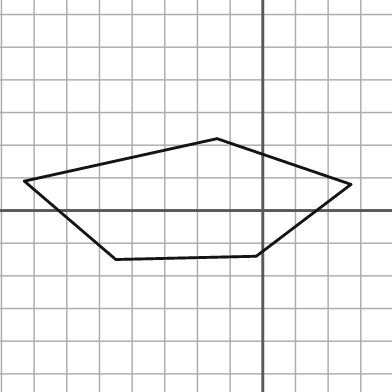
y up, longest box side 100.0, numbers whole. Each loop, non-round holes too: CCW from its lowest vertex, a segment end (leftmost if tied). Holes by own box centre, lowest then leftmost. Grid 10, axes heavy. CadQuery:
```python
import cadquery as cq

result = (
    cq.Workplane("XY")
    .moveTo(-45.0, -15.0)
    .lineTo(-2.0, -14.0)
    .lineTo(27.0, 8.0)
    .lineTo(-14.0, 22.0)
    .lineTo(-73.0, 9.0)
    .close()
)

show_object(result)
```